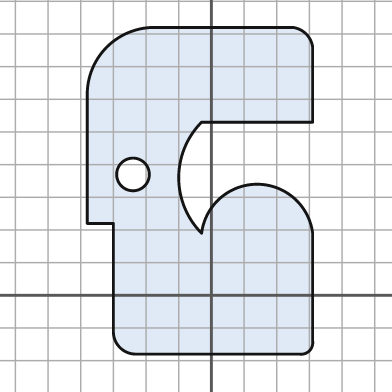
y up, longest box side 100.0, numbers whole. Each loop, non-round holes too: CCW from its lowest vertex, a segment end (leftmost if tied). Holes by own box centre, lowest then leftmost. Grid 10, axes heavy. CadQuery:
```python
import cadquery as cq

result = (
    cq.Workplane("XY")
    .moveTo(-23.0, -18.0)
    .lineTo(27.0, -18.0)
    .threePointArc((30.0, -17.0), (31.0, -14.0))
    .lineTo(31.0, 19.0)
    .threePointArc((14.0, 34.0), (-3.0, 19.0))
    .threePointArc((-10.0, 36.0), (-3.0, 53.0))
    .lineTo(31.0, 53.0)
    .lineTo(31.0, 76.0)
    .threePointArc((29.0, 80.0), (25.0, 82.0))
    .lineTo(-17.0, 82.0)
    .threePointArc((-32.0, 76.0), (-38.0, 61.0))
    .lineTo(-38.0, 22.0)
    .lineTo(-30.0, 22.0)
    .lineTo(-30.0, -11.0)
    .threePointArc((-28.0, -16.0), (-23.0, -18.0))
    .close()
    .moveTo(-24.0, 37.0)
    .circle(5.0)
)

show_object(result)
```